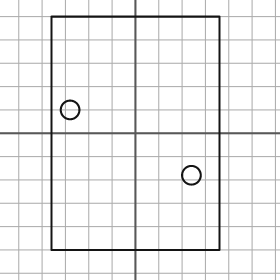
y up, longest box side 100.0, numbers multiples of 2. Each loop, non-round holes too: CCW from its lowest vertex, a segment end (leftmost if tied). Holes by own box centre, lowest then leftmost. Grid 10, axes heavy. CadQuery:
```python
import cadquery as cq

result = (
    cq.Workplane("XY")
    .moveTo(-36.0, -50.0)
    .lineTo(36.0, -50.0)
    .lineTo(36.0, 50.0)
    .lineTo(-36.0, 50.0)
    .close()
    .moveTo(24.0, -18.0)
    .circle(4.0)
    .moveTo(-28.0, 10.0)
    .circle(4.0)
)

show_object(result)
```